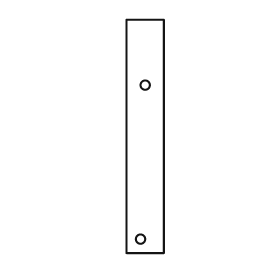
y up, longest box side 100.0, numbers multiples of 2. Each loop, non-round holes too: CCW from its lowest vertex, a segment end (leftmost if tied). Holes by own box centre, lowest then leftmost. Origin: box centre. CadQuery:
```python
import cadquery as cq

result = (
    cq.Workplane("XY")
    .moveTo(-8.0, -50.0)
    .lineTo(8.0, -50.0)
    .lineTo(8.0, 50.0)
    .lineTo(-8.0, 50.0)
    .close()
    .moveTo(-2.0, -44.0)
    .circle(2.0)
    .moveTo(0.0, 22.0)
    .circle(2.0)
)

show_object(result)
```